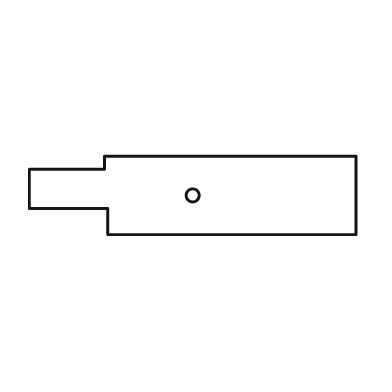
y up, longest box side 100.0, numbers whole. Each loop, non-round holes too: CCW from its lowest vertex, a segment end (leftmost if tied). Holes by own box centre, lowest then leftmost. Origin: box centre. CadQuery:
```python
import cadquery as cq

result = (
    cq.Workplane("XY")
    .moveTo(-26.0, -12.0)
    .lineTo(50.0, -12.0)
    .lineTo(50.0, 12.0)
    .lineTo(-27.0, 12.0)
    .lineTo(-27.0, 8.0)
    .lineTo(-50.0, 8.0)
    .lineTo(-50.0, -4.0)
    .lineTo(-26.0, -4.0)
    .close()
    .moveTo(0.0, 0.0)
    .circle(2.0)
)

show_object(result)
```